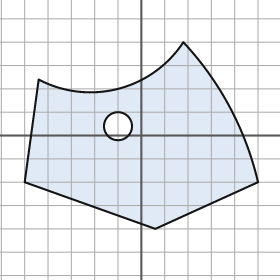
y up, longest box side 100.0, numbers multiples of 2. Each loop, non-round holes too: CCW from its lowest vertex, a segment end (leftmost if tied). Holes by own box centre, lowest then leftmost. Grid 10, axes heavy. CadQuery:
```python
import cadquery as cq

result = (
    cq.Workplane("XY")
    .moveTo(6.0, -40.0)
    .lineTo(50.0, -20.0)
    .threePointArc((38.0, 12.0), (18.0, 40.0))
    .threePointArc((-10.0, 20.0), (-44.0, 24.0))
    .lineTo(-50.0, -20.0)
    .close()
    .moveTo(-10.0, 4.0)
    .circle(6.0)
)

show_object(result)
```